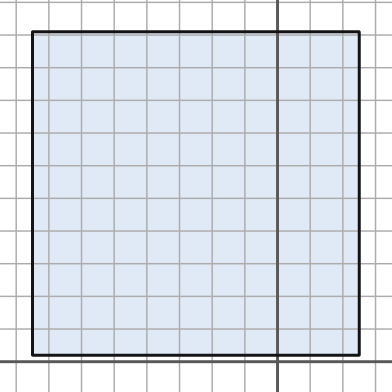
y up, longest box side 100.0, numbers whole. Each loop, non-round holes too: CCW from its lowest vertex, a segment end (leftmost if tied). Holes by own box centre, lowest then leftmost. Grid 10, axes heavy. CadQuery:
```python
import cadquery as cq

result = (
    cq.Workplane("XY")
    .moveTo(-75.0, 2.0)
    .lineTo(25.0, 2.0)
    .lineTo(25.0, 101.0)
    .lineTo(-75.0, 101.0)
    .close()
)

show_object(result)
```